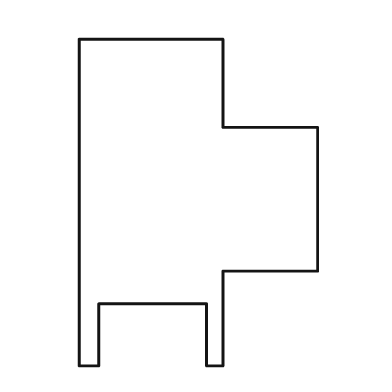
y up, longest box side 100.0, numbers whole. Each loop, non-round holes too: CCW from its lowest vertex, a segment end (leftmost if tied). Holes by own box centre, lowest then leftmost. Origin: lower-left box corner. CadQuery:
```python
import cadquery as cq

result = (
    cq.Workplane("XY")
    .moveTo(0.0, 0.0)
    .lineTo(6.0, 0.0)
    .lineTo(6.0, 19.0)
    .lineTo(39.0, 19.0)
    .lineTo(39.0, 0.0)
    .lineTo(44.0, 0.0)
    .lineTo(44.0, 29.0)
    .lineTo(73.0, 29.0)
    .lineTo(73.0, 73.0)
    .lineTo(44.0, 73.0)
    .lineTo(44.0, 100.0)
    .lineTo(0.0, 100.0)
    .close()
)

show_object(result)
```